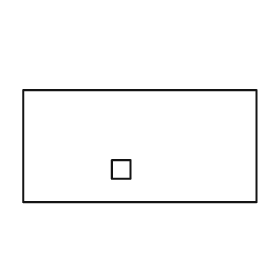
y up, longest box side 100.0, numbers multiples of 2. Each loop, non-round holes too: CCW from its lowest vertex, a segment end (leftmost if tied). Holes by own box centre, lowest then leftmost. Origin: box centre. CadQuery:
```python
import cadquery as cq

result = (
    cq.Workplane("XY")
    .moveTo(-50.0, -24.0)
    .lineTo(50.0, -24.0)
    .lineTo(50.0, 24.0)
    .lineTo(-50.0, 24.0)
    .close()
    .moveTo(-12.0, -14.0)
    .lineTo(-4.0, -14.0)
    .lineTo(-4.0, -6.0)
    .lineTo(-12.0, -6.0)
    .close()
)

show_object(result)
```